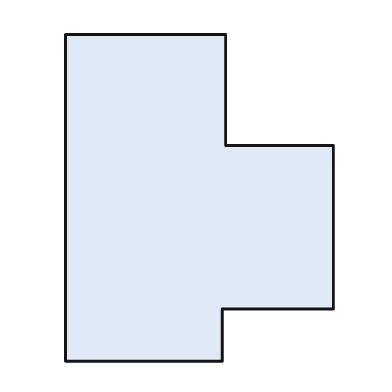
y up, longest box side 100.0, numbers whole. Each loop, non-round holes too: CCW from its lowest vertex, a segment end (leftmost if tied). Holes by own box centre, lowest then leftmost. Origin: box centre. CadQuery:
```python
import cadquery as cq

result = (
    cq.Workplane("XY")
    .moveTo(-41.0, -50.0)
    .lineTo(7.0, -50.0)
    .lineTo(7.0, -34.0)
    .lineTo(41.0, -34.0)
    .lineTo(41.0, 16.0)
    .lineTo(8.0, 16.0)
    .lineTo(8.0, 50.0)
    .lineTo(-41.0, 50.0)
    .close()
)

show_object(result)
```